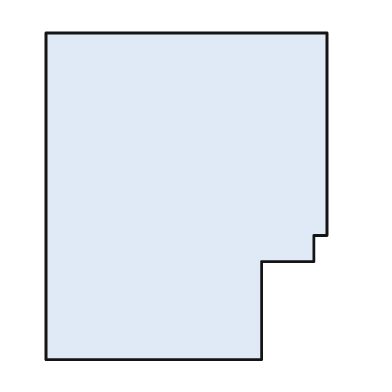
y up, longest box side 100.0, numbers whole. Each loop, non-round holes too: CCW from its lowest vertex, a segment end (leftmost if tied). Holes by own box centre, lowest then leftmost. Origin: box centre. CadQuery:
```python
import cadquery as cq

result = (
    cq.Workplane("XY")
    .moveTo(-43.0, -50.0)
    .lineTo(23.0, -50.0)
    .lineTo(23.0, -20.0)
    .lineTo(39.0, -20.0)
    .lineTo(39.0, -12.0)
    .lineTo(43.0, -12.0)
    .lineTo(43.0, 50.0)
    .lineTo(-43.0, 50.0)
    .close()
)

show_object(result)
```